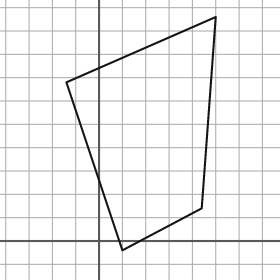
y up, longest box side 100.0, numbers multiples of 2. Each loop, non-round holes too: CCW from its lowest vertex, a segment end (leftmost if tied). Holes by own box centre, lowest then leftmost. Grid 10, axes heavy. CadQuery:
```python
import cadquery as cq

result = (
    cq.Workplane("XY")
    .moveTo(10.0, -4.0)
    .lineTo(44.0, 14.0)
    .lineTo(50.0, 96.0)
    .lineTo(-14.0, 68.0)
    .close()
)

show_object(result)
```